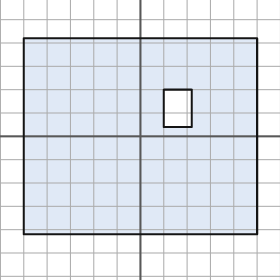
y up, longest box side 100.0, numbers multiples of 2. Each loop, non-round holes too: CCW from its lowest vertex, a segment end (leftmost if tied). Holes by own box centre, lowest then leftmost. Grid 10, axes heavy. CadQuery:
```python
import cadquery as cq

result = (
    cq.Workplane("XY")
    .moveTo(-50.0, -42.0)
    .lineTo(50.0, -42.0)
    .lineTo(50.0, 42.0)
    .lineTo(-50.0, 42.0)
    .close()
    .moveTo(10.0, 4.0)
    .lineTo(22.0, 4.0)
    .lineTo(22.0, 20.0)
    .lineTo(10.0, 20.0)
    .close()
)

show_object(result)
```